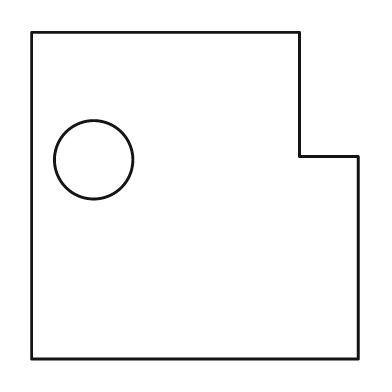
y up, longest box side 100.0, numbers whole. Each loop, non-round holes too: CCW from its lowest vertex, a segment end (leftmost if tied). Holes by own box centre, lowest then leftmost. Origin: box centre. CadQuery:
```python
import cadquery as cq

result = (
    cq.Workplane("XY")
    .moveTo(-50.0, -50.0)
    .lineTo(50.0, -50.0)
    .lineTo(50.0, 12.0)
    .lineTo(32.0, 12.0)
    .lineTo(32.0, 50.0)
    .lineTo(-50.0, 50.0)
    .close()
    .moveTo(-31.0, 11.0)
    .circle(12.0)
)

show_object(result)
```